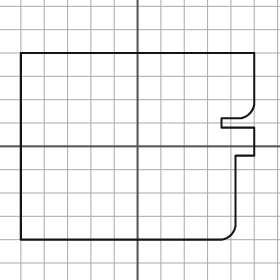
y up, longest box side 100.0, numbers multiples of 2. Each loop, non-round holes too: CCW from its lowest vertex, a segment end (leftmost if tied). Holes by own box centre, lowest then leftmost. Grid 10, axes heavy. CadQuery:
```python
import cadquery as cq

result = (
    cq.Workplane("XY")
    .moveTo(-50.0, -40.0)
    .lineTo(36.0, -40.0)
    .threePointArc((40.0, -38.0), (42.0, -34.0))
    .lineTo(42.0, -4.0)
    .lineTo(50.0, -4.0)
    .lineTo(50.0, 8.0)
    .lineTo(36.0, 8.0)
    .lineTo(36.0, 12.0)
    .lineTo(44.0, 12.0)
    .threePointArc((48.0, 14.0), (50.0, 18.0))
    .lineTo(50.0, 40.0)
    .lineTo(-50.0, 40.0)
    .close()
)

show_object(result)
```